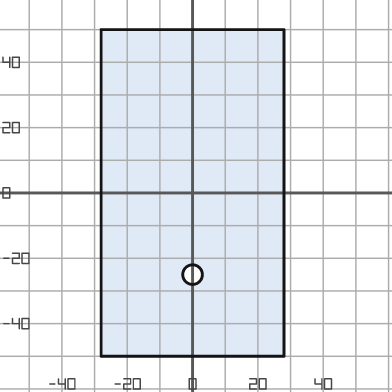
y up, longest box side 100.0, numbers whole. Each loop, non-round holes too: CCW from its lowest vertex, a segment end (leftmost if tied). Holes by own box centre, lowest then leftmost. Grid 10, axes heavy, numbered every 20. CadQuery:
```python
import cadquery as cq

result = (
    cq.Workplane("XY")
    .moveTo(-28.0, -50.0)
    .lineTo(28.0, -50.0)
    .lineTo(28.0, 50.0)
    .lineTo(-28.0, 50.0)
    .close()
    .moveTo(0.0, -25.0)
    .circle(3.0)
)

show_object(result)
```